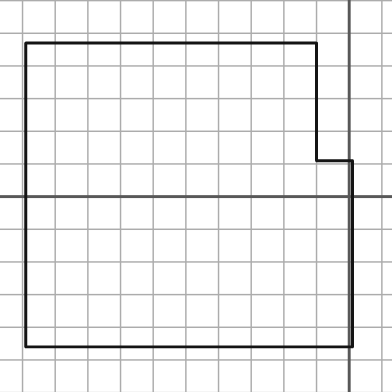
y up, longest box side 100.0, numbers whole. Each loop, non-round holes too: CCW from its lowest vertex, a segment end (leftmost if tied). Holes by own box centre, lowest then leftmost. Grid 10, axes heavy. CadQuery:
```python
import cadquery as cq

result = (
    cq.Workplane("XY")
    .moveTo(-99.0, -46.0)
    .lineTo(1.0, -46.0)
    .lineTo(1.0, 11.0)
    .lineTo(-10.0, 11.0)
    .lineTo(-10.0, 47.0)
    .lineTo(-99.0, 47.0)
    .close()
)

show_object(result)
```